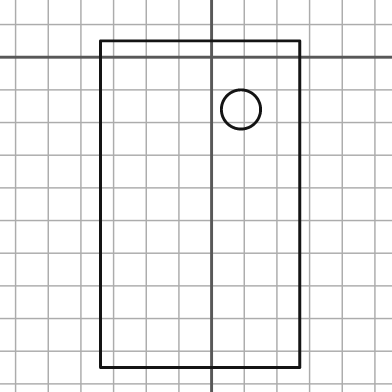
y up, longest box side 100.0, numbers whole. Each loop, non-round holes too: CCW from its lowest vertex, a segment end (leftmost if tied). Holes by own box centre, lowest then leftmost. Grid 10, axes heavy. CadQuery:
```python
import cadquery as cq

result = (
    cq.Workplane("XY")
    .moveTo(-34.0, -95.0)
    .lineTo(27.0, -95.0)
    .lineTo(27.0, 5.0)
    .lineTo(-34.0, 5.0)
    .close()
    .moveTo(9.0, -16.0)
    .circle(6.0)
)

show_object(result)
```